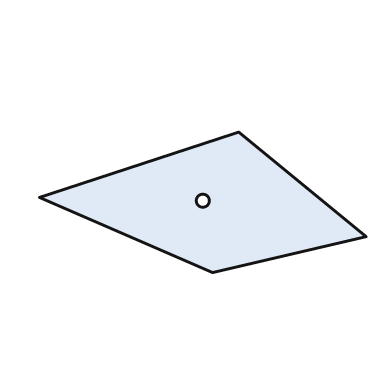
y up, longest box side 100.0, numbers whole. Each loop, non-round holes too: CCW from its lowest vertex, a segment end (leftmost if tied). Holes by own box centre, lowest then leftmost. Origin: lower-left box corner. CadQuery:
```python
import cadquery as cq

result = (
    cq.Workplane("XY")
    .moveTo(53.0, 0.0)
    .lineTo(100.0, 11.0)
    .lineTo(61.0, 43.0)
    .lineTo(0.0, 23.0)
    .close()
    .moveTo(50.0, 22.0)
    .circle(2.0)
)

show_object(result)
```